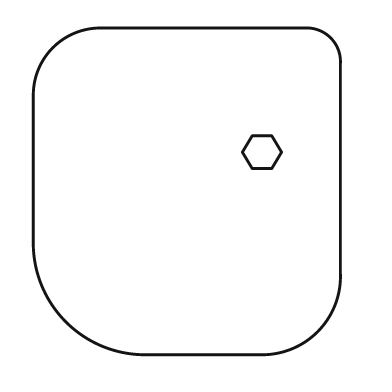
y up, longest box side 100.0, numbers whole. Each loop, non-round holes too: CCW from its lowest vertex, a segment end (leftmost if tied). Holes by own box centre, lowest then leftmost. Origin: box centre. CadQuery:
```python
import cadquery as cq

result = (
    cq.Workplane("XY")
    .moveTo(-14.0, -50.0)
    .lineTo(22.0, -50.0)
    .threePointArc((40.0, -43.0), (47.0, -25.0))
    .lineTo(47.0, 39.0)
    .threePointArc((44.0, 47.0), (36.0, 50.0))
    .lineTo(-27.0, 50.0)
    .threePointArc((-41.0, 44.0), (-47.0, 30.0))
    .lineTo(-47.0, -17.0)
    .threePointArc((-37.0, -40.0), (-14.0, -50.0))
    .close()
    .moveTo(20.0, 7.0)
    .lineTo(26.0, 7.0)
    .lineTo(29.0, 12.0)
    .lineTo(26.0, 17.0)
    .lineTo(20.0, 17.0)
    .lineTo(17.0, 12.0)
    .close()
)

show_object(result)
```